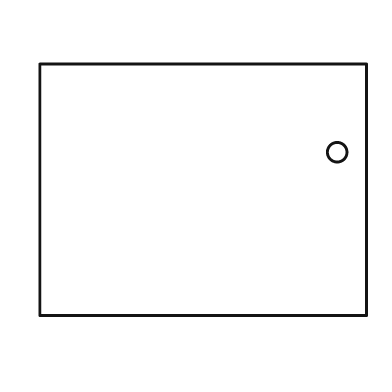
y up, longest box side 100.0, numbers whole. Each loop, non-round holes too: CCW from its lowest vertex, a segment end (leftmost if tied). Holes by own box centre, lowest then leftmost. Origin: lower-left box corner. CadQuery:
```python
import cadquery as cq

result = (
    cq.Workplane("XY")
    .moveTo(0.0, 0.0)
    .lineTo(100.0, 0.0)
    .lineTo(100.0, 77.0)
    .lineTo(0.0, 77.0)
    .close()
    .moveTo(91.0, 50.0)
    .circle(3.0)
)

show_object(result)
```